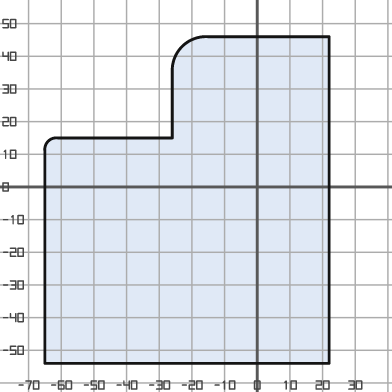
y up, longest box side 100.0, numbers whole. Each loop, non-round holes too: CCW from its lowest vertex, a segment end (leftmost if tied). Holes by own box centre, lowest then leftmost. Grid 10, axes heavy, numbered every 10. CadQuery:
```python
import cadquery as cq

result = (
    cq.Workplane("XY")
    .moveTo(-65.0, -54.0)
    .lineTo(22.0, -54.0)
    .lineTo(22.0, 46.0)
    .lineTo(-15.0, 46.0)
    .threePointArc((-23.0, 43.0), (-26.0, 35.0))
    .lineTo(-26.0, 15.0)
    .lineTo(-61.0, 15.0)
    .threePointArc((-64.0, 14.0), (-65.0, 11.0))
    .close()
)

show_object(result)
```